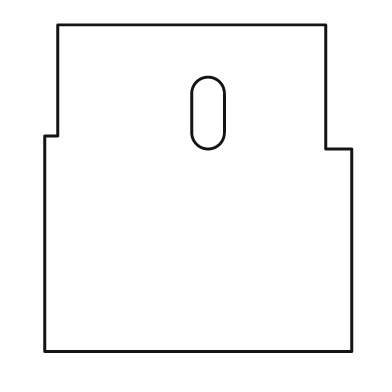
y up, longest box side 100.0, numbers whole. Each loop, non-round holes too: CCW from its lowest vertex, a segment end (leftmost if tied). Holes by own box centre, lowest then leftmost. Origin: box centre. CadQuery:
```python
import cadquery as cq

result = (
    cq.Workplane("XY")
    .moveTo(-47.0, -50.0)
    .lineTo(47.0, -50.0)
    .lineTo(47.0, 12.0)
    .lineTo(39.0, 12.0)
    .lineTo(39.0, 50.0)
    .lineTo(-43.0, 50.0)
    .lineTo(-43.0, 16.0)
    .lineTo(-47.0, 16.0)
    .close()
    .moveTo(-2.0, 17.0)
    .threePointArc((3.0, 12.0), (8.0, 17.0))
    .lineTo(8.0, 29.0)
    .threePointArc((3.0, 34.0), (-2.0, 29.0))
    .close()
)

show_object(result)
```